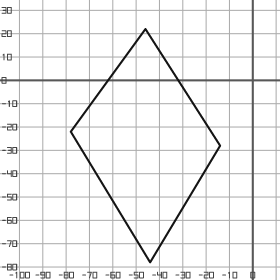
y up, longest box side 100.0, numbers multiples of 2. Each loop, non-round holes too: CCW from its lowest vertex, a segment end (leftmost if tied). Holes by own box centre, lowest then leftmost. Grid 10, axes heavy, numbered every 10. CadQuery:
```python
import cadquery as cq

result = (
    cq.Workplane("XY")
    .moveTo(-44.0, -78.0)
    .lineTo(-14.0, -28.0)
    .lineTo(-46.0, 22.0)
    .lineTo(-78.0, -22.0)
    .close()
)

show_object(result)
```